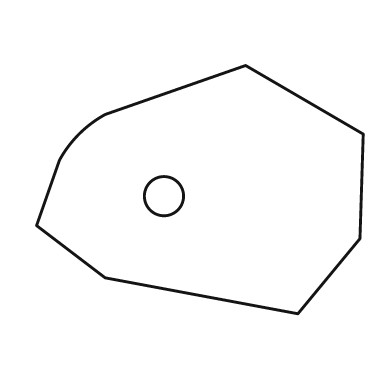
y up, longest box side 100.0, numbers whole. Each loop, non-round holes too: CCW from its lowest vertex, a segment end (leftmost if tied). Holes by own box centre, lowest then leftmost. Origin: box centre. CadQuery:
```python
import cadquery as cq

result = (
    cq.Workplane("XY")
    .moveTo(30.0, -38.0)
    .lineTo(49.0, -15.0)
    .lineTo(50.0, 17.0)
    .lineTo(14.0, 38.0)
    .lineTo(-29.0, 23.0)
    .threePointArc((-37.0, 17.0), (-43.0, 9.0))
    .lineTo(-50.0, -11.0)
    .lineTo(-29.0, -27.0)
    .close()
    .moveTo(-11.0, -2.0)
    .circle(6.0)
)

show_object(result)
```